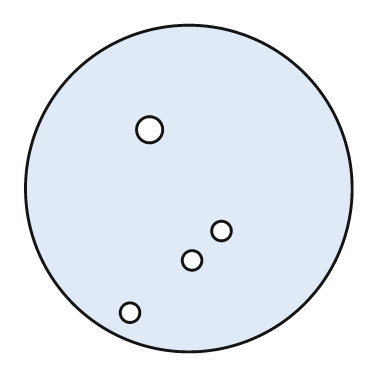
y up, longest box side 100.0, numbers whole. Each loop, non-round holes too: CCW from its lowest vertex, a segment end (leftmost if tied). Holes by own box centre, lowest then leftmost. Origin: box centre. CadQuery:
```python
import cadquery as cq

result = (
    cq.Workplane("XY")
    .moveTo(0.0, 0.0)
    .circle(50.0)
    .moveTo(-18.0, -38.0)
    .circle(3.0)
    .moveTo(1.0, -22.0)
    .circle(3.0)
    .moveTo(10.0, -13.0)
    .circle(3.0)
    .moveTo(-12.0, 18.0)
    .circle(4.0)
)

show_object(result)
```